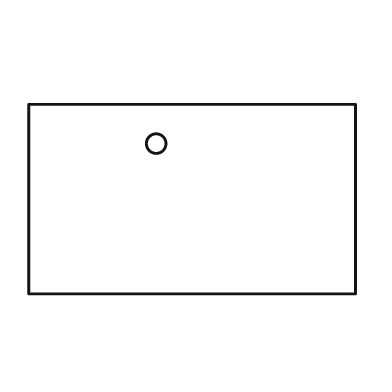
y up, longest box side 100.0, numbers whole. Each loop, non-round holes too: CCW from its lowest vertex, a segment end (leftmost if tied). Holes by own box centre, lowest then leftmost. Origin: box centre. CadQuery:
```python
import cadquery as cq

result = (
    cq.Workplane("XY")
    .moveTo(-50.0, -29.0)
    .lineTo(50.0, -29.0)
    .lineTo(50.0, 29.0)
    .lineTo(-50.0, 29.0)
    .close()
    .moveTo(-11.0, 17.0)
    .circle(3.0)
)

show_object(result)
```